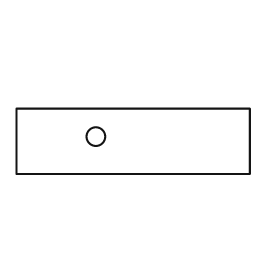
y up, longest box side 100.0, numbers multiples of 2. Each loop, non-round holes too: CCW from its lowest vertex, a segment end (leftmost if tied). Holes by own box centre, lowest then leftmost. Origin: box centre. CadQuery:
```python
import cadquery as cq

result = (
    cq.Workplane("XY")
    .moveTo(-50.0, -14.0)
    .lineTo(50.0, -14.0)
    .lineTo(50.0, 14.0)
    .lineTo(-50.0, 14.0)
    .close()
    .moveTo(-16.0, 2.0)
    .circle(4.0)
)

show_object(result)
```